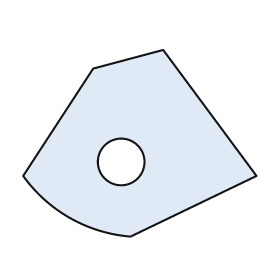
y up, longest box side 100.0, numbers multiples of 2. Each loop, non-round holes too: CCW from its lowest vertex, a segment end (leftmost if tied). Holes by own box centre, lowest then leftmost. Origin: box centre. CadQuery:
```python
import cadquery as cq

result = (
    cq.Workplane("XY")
    .moveTo(-4.0, -40.0)
    .lineTo(50.0, -14.0)
    .lineTo(10.0, 40.0)
    .lineTo(-20.0, 32.0)
    .lineTo(-50.0, -14.0)
    .threePointArc((-30.0, -32.0), (-4.0, -40.0))
    .close()
    .moveTo(-8.0, -8.0)
    .circle(10.0)
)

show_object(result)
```